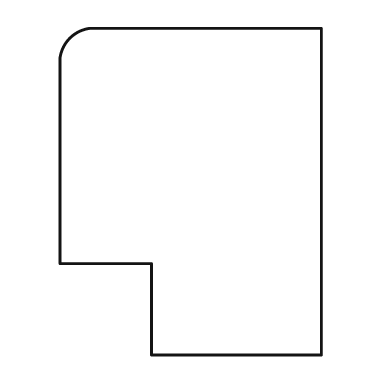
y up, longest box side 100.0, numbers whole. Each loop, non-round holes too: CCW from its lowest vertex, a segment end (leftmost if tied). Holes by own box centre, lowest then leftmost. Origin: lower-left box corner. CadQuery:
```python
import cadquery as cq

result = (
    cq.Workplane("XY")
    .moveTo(28.0, 0.0)
    .lineTo(80.0, 0.0)
    .lineTo(80.0, 100.0)
    .lineTo(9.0, 100.0)
    .threePointArc((3.0, 97.0), (0.0, 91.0))
    .lineTo(0.0, 28.0)
    .lineTo(28.0, 28.0)
    .close()
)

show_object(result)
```